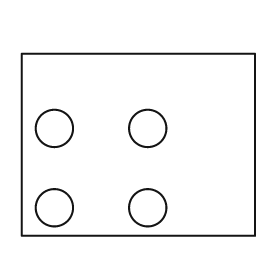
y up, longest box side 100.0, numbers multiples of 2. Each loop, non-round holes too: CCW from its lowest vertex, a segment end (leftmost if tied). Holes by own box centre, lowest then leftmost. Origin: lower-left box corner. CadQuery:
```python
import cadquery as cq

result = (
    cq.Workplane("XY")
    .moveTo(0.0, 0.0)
    .lineTo(100.0, 0.0)
    .lineTo(100.0, 78.0)
    .lineTo(0.0, 78.0)
    .close()
    .moveTo(14.0, 12.0)
    .circle(8.0)
    .moveTo(54.0, 12.0)
    .circle(8.0)
    .moveTo(14.0, 46.0)
    .circle(8.0)
    .moveTo(54.0, 46.0)
    .circle(8.0)
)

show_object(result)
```